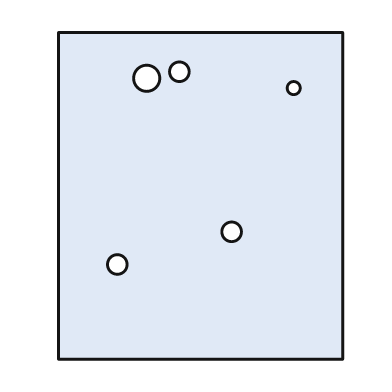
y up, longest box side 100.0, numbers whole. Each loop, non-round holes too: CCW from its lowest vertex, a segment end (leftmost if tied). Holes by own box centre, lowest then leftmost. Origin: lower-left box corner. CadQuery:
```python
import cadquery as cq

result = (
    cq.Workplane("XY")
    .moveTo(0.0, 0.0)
    .lineTo(87.0, 0.0)
    .lineTo(87.0, 100.0)
    .lineTo(0.0, 100.0)
    .close()
    .moveTo(18.0, 29.0)
    .circle(3.0)
    .moveTo(53.0, 39.0)
    .circle(3.0)
    .moveTo(72.0, 83.0)
    .circle(2.0)
    .moveTo(27.0, 86.0)
    .circle(4.0)
    .moveTo(37.0, 88.0)
    .circle(3.0)
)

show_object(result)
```